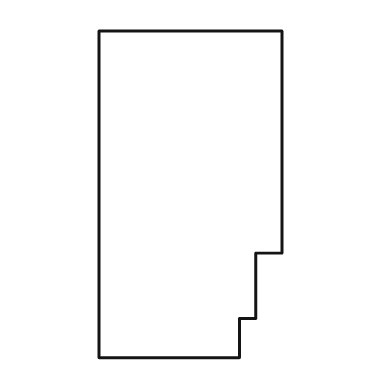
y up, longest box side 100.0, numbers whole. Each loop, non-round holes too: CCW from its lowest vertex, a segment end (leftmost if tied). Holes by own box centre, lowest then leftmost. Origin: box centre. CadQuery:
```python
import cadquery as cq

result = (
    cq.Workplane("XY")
    .moveTo(-28.0, -50.0)
    .lineTo(15.0, -50.0)
    .lineTo(15.0, -38.0)
    .lineTo(20.0, -38.0)
    .lineTo(20.0, -18.0)
    .lineTo(28.0, -18.0)
    .lineTo(28.0, 50.0)
    .lineTo(-28.0, 50.0)
    .close()
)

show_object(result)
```